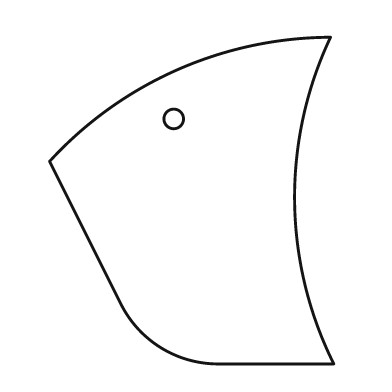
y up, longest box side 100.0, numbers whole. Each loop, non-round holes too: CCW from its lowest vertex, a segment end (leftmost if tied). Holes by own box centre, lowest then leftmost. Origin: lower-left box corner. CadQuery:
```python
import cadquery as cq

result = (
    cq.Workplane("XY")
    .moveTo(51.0, 0.0)
    .lineTo(87.0, 0.0)
    .threePointArc((75.0, 50.0), (86.0, 100.0))
    .threePointArc((39.0, 90.0), (0.0, 62.0))
    .lineTo(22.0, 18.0)
    .threePointArc((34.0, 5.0), (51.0, 0.0))
    .close()
    .moveTo(38.0, 75.0)
    .circle(3.0)
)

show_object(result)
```